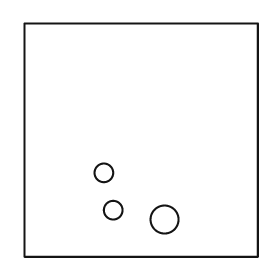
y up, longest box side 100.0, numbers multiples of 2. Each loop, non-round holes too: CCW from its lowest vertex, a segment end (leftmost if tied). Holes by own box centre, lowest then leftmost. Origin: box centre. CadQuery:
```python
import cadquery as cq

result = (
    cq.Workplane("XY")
    .moveTo(-50.0, -50.0)
    .lineTo(50.0, -50.0)
    .lineTo(50.0, 50.0)
    .lineTo(-50.0, 50.0)
    .close()
    .moveTo(10.0, -34.0)
    .circle(6.0)
    .moveTo(-12.0, -30.0)
    .circle(4.0)
    .moveTo(-16.0, -14.0)
    .circle(4.0)
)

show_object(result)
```